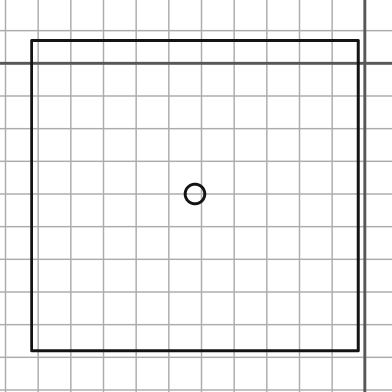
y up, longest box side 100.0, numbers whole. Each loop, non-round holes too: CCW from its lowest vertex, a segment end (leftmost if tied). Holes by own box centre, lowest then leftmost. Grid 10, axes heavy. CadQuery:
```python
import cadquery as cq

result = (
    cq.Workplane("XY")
    .moveTo(-102.0, -88.0)
    .lineTo(-2.0, -88.0)
    .lineTo(-2.0, 7.0)
    .lineTo(-102.0, 7.0)
    .close()
    .moveTo(-52.0, -40.0)
    .circle(3.0)
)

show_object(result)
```